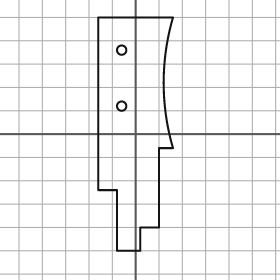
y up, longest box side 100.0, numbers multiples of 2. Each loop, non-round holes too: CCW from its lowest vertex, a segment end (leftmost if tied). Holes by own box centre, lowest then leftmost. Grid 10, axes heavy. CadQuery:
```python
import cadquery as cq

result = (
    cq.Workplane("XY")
    .moveTo(-8.0, -50.0)
    .lineTo(2.0, -50.0)
    .lineTo(2.0, -40.0)
    .lineTo(10.0, -40.0)
    .lineTo(10.0, -6.0)
    .lineTo(16.0, -6.0)
    .threePointArc((12.0, 22.0), (16.0, 50.0))
    .lineTo(-16.0, 50.0)
    .lineTo(-16.0, -24.0)
    .lineTo(-8.0, -24.0)
    .close()
    .moveTo(-6.0, 12.0)
    .circle(2.0)
    .moveTo(-6.0, 36.0)
    .circle(2.0)
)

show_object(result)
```